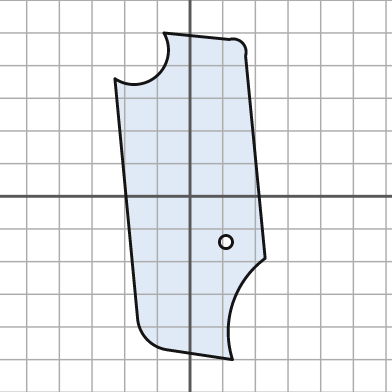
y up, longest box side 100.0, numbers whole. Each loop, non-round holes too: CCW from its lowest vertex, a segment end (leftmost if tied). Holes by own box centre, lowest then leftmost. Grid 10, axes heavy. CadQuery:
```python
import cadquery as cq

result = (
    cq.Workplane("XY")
    .moveTo(13.0, -50.0)
    .threePointArc((13.0, -33.0), (23.0, -19.0))
    .lineTo(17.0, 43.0)
    .threePointArc((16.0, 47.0), (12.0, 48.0))
    .lineTo(-8.0, 50.0)
    .threePointArc((-10.0, 37.0), (-23.0, 36.0))
    .lineTo(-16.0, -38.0)
    .threePointArc((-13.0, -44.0), (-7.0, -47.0))
    .close()
    .moveTo(11.0, -14.0)
    .circle(2.0)
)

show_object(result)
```